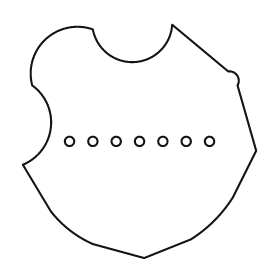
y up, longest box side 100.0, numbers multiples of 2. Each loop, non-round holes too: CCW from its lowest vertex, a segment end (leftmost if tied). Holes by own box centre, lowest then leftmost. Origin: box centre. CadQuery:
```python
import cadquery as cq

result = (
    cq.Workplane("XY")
    .moveTo(2.0, -50.0)
    .lineTo(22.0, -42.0)
    .threePointArc((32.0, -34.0), (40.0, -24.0))
    .lineTo(50.0, -4.0)
    .lineTo(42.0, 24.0)
    .threePointArc((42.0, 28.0), (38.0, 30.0))
    .lineTo(14.0, 50.0)
    .threePointArc((-2.0, 34.0), (-20.0, 48.0))
    .threePointArc((-40.0, 44.0), (-46.0, 24.0))
    .threePointArc((-38.0, 6.0), (-50.0, -10.0))
    .lineTo(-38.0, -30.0)
    .threePointArc((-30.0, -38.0), (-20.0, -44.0))
    .close()
    .moveTo(-30.0, 0.0)
    .circle(2.0)
    .moveTo(-20.0, 0.0)
    .circle(2.0)
    .moveTo(-10.0, 0.0)
    .circle(2.0)
    .moveTo(0.0, 0.0)
    .circle(2.0)
    .moveTo(10.0, 0.0)
    .circle(2.0)
    .moveTo(20.0, 0.0)
    .circle(2.0)
    .moveTo(30.0, 0.0)
    .circle(2.0)
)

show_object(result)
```